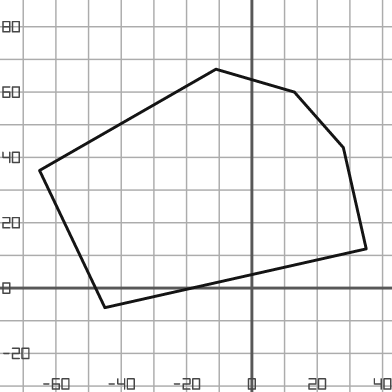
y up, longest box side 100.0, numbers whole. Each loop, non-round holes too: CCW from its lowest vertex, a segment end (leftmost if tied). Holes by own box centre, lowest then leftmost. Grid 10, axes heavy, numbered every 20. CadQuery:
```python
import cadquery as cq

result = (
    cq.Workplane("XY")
    .moveTo(-45.0, -6.0)
    .lineTo(35.0, 12.0)
    .lineTo(28.0, 43.0)
    .lineTo(13.0, 60.0)
    .lineTo(-11.0, 67.0)
    .lineTo(-65.0, 36.0)
    .close()
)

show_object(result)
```